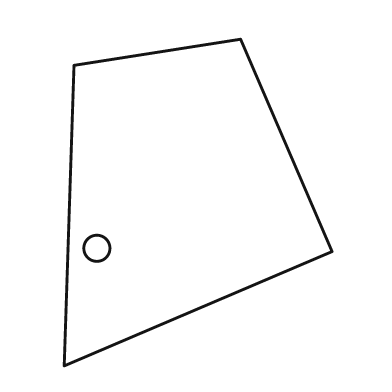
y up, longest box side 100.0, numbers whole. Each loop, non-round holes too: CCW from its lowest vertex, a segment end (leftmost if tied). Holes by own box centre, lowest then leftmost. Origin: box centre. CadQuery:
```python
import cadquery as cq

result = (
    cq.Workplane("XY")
    .moveTo(-41.0, -50.0)
    .lineTo(41.0, -15.0)
    .lineTo(13.0, 50.0)
    .lineTo(-38.0, 42.0)
    .close()
    .moveTo(-31.0, -14.0)
    .circle(4.0)
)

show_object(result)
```